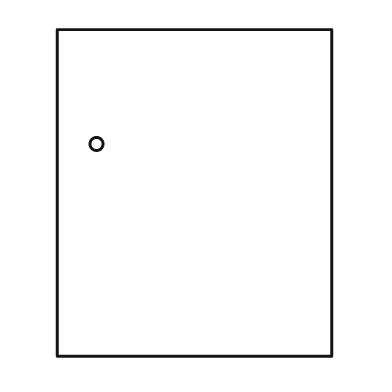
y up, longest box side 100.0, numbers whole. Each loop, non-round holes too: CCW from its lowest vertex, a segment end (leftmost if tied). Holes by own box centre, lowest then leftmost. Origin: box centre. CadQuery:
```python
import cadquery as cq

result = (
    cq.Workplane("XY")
    .moveTo(-42.0, -50.0)
    .lineTo(42.0, -50.0)
    .lineTo(42.0, 50.0)
    .lineTo(-42.0, 50.0)
    .close()
    .moveTo(-30.0, 15.0)
    .circle(2.0)
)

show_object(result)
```